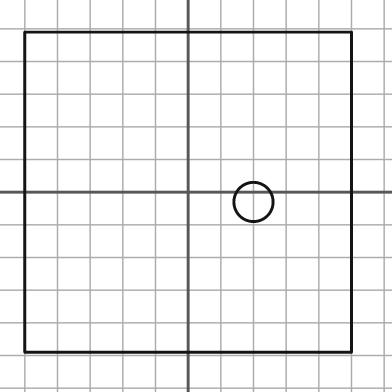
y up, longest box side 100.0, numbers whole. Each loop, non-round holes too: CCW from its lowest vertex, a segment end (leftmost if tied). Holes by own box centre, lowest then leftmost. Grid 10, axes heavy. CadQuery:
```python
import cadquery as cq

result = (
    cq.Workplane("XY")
    .moveTo(-50.0, -49.0)
    .lineTo(50.0, -49.0)
    .lineTo(50.0, 49.0)
    .lineTo(-50.0, 49.0)
    .close()
    .moveTo(20.0, -3.0)
    .circle(6.0)
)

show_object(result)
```